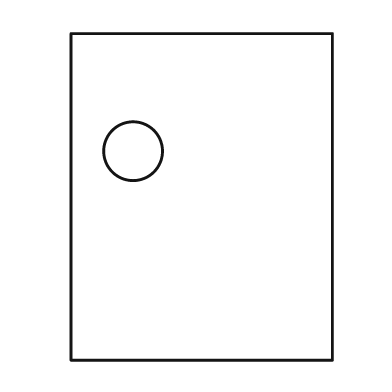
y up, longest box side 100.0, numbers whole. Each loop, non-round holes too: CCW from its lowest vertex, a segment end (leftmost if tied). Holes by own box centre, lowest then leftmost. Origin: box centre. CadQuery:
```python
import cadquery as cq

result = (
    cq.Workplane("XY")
    .moveTo(-40.0, -50.0)
    .lineTo(40.0, -50.0)
    .lineTo(40.0, 50.0)
    .lineTo(-40.0, 50.0)
    .close()
    .moveTo(-21.0, 14.0)
    .circle(9.0)
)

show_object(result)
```